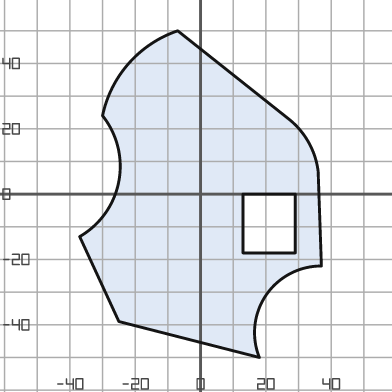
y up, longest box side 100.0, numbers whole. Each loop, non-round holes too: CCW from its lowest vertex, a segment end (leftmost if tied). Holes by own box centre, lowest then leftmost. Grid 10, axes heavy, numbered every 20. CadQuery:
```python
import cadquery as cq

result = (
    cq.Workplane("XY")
    .moveTo(18.0, -50.0)
    .threePointArc((20.0, -31.0), (37.0, -22.0))
    .lineTo(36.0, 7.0)
    .threePointArc((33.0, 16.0), (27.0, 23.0))
    .lineTo(-7.0, 50.0)
    .threePointArc((-22.0, 40.0), (-30.0, 24.0))
    .threePointArc((-25.0, 4.0), (-37.0, -13.0))
    .lineTo(-25.0, -39.0)
    .close()
    .moveTo(13.0, -18.0)
    .lineTo(29.0, -18.0)
    .lineTo(29.0, 0.0)
    .lineTo(13.0, 0.0)
    .close()
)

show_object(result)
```